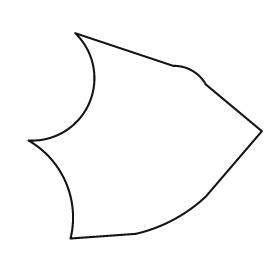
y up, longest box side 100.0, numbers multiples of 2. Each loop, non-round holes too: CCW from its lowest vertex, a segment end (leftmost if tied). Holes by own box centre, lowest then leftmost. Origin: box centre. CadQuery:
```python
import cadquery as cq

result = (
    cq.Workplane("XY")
    .moveTo(-32.0, -44.0)
    .lineTo(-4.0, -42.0)
    .threePointArc((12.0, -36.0), (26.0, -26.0))
    .lineTo(50.0, 2.0)
    .lineTo(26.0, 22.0)
    .threePointArc((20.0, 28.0), (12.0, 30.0))
    .lineTo(-30.0, 44.0)
    .threePointArc((-24.0, 14.0), (-50.0, -2.0))
    .threePointArc((-34.0, -20.0), (-32.0, -44.0))
    .close()
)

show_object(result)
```